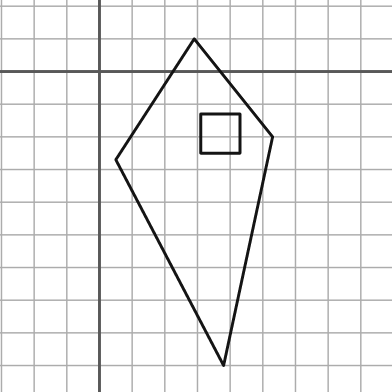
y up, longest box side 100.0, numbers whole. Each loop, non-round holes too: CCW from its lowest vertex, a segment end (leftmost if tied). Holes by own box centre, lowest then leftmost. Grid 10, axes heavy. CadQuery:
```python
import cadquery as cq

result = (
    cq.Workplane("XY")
    .moveTo(38.0, -90.0)
    .lineTo(53.0, -20.0)
    .lineTo(29.0, 10.0)
    .lineTo(5.0, -27.0)
    .close()
    .moveTo(31.0, -25.0)
    .lineTo(43.0, -25.0)
    .lineTo(43.0, -13.0)
    .lineTo(31.0, -13.0)
    .close()
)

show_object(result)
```